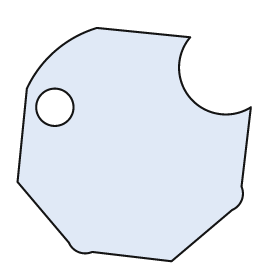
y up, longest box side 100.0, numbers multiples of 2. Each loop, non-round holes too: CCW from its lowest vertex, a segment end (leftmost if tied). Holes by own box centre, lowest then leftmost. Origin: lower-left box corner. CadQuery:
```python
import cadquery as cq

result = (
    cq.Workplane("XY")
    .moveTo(66.0, 0.0)
    .lineTo(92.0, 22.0)
    .threePointArc((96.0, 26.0), (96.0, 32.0))
    .lineTo(100.0, 66.0)
    .threePointArc((74.0, 70.0), (74.0, 96.0))
    .lineTo(34.0, 100.0)
    .threePointArc((16.0, 90.0), (4.0, 74.0))
    .lineTo(0.0, 34.0)
    .lineTo(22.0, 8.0)
    .threePointArc((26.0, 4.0), (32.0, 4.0))
    .close()
    .moveTo(16.0, 66.0)
    .circle(8.0)
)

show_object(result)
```